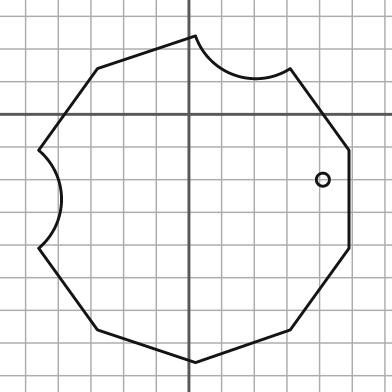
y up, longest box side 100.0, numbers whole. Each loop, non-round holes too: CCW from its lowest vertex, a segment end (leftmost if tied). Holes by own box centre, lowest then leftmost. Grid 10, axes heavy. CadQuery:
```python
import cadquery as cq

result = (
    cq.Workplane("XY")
    .moveTo(2.0, -76.0)
    .lineTo(31.0, -66.0)
    .lineTo(49.0, -41.0)
    .lineTo(49.0, -11.0)
    .lineTo(31.0, 14.0)
    .threePointArc((14.0, 12.0), (2.0, 24.0))
    .lineTo(-28.0, 14.0)
    .lineTo(-46.0, -11.0)
    .threePointArc((-39.0, -26.0), (-46.0, -41.0))
    .lineTo(-28.0, -66.0)
    .close()
    .moveTo(41.0, -20.0)
    .circle(2.0)
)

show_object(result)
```